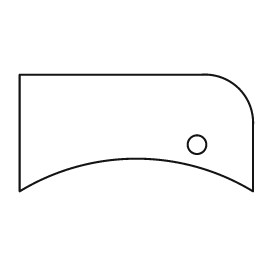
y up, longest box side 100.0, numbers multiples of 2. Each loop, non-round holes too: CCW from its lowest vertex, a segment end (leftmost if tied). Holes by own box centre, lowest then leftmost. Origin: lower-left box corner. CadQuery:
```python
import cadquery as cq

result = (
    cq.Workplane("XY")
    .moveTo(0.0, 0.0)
    .threePointArc((50.0, 14.0), (100.0, 0.0))
    .lineTo(100.0, 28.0)
    .threePointArc((94.0, 44.0), (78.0, 50.0))
    .lineTo(0.0, 50.0)
    .close()
    .moveTo(76.0, 20.0)
    .circle(4.0)
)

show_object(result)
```